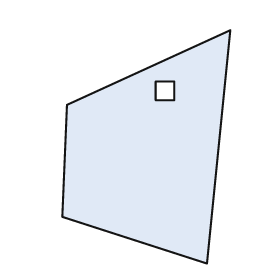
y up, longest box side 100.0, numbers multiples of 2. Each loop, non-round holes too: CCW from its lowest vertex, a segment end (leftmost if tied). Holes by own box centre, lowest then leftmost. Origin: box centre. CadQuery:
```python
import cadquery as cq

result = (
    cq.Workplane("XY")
    .moveTo(26.0, -50.0)
    .lineTo(36.0, 50.0)
    .lineTo(-34.0, 18.0)
    .lineTo(-36.0, -30.0)
    .close()
    .moveTo(4.0, 20.0)
    .lineTo(12.0, 20.0)
    .lineTo(12.0, 28.0)
    .lineTo(4.0, 28.0)
    .close()
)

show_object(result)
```